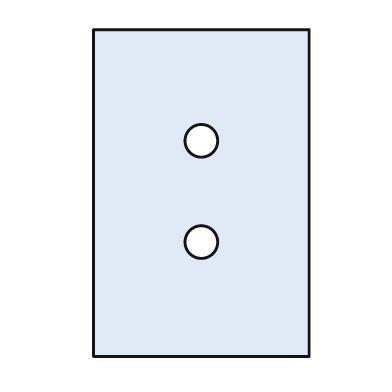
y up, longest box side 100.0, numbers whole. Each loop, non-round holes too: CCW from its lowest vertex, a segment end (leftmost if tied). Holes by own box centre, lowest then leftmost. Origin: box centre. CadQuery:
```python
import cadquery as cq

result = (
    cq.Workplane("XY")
    .moveTo(-33.0, -50.0)
    .lineTo(33.0, -50.0)
    .lineTo(33.0, 50.0)
    .lineTo(-33.0, 50.0)
    .close()
    .moveTo(0.0, -15.0)
    .circle(5.0)
    .moveTo(0.0, 16.0)
    .circle(5.0)
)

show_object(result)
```